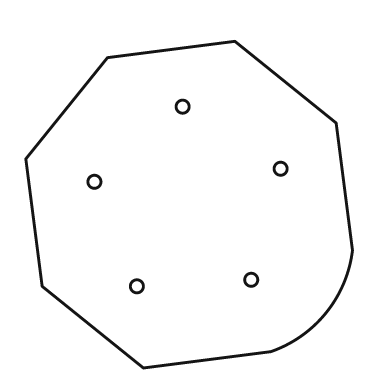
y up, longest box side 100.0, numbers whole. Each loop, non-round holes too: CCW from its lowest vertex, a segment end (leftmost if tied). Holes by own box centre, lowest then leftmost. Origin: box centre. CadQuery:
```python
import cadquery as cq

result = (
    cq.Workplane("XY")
    .moveTo(-14.0, -50.0)
    .lineTo(25.0, -45.0)
    .threePointArc((42.0, -33.0), (50.0, -14.0))
    .lineTo(45.0, 25.0)
    .lineTo(14.0, 50.0)
    .lineTo(-25.0, 45.0)
    .lineTo(-50.0, 14.0)
    .lineTo(-45.0, -25.0)
    .close()
    .moveTo(-16.0, -25.0)
    .circle(2.0)
    .moveTo(19.0, -23.0)
    .circle(2.0)
    .moveTo(-29.0, 7.0)
    .circle(2.0)
    .moveTo(28.0, 11.0)
    .circle(2.0)
    .moveTo(-2.0, 30.0)
    .circle(2.0)
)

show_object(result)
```